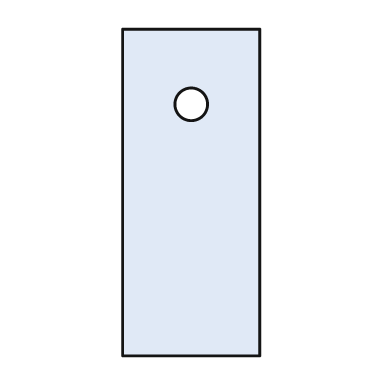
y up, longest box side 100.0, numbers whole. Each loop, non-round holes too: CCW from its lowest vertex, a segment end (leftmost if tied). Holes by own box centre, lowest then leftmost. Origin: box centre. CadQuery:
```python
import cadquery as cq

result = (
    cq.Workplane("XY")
    .moveTo(-21.0, -50.0)
    .lineTo(21.0, -50.0)
    .lineTo(21.0, 50.0)
    .lineTo(-21.0, 50.0)
    .close()
    .moveTo(0.0, 27.0)
    .circle(5.0)
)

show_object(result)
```